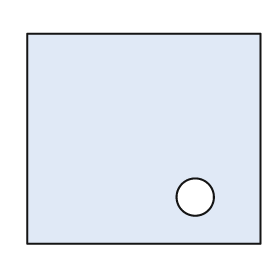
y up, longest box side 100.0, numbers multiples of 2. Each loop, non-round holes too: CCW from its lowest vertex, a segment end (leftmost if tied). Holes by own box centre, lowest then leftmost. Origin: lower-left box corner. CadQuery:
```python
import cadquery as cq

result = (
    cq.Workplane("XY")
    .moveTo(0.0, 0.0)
    .lineTo(100.0, 0.0)
    .lineTo(100.0, 90.0)
    .lineTo(0.0, 90.0)
    .close()
    .moveTo(72.0, 20.0)
    .circle(8.0)
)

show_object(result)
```